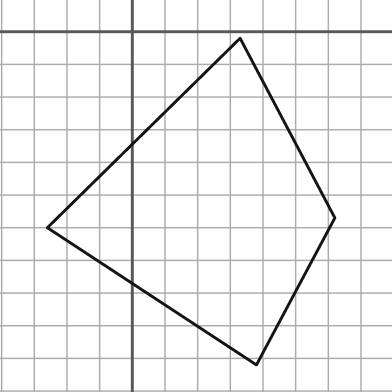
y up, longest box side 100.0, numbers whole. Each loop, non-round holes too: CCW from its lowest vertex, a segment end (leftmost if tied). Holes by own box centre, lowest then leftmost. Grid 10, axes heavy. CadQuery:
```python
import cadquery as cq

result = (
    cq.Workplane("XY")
    .moveTo(38.0, -102.0)
    .lineTo(62.0, -57.0)
    .lineTo(33.0, -2.0)
    .lineTo(-26.0, -60.0)
    .close()
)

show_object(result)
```